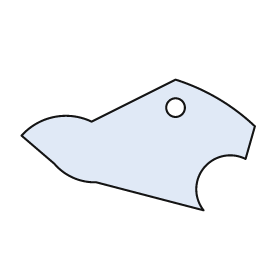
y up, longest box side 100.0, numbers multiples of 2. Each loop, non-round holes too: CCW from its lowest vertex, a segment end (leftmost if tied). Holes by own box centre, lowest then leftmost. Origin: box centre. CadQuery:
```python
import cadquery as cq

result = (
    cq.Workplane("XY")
    .moveTo(28.0, -28.0)
    .threePointArc((28.0, -10.0), (46.0, -6.0))
    .lineTo(50.0, 8.0)
    .threePointArc((34.0, 20.0), (16.0, 28.0))
    .lineTo(-20.0, 10.0)
    .threePointArc((-36.0, 12.0), (-50.0, 4.0))
    .lineTo(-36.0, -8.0)
    .threePointArc((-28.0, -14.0), (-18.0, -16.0))
    .close()
    .moveTo(16.0, 16.0)
    .circle(4.0)
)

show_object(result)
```